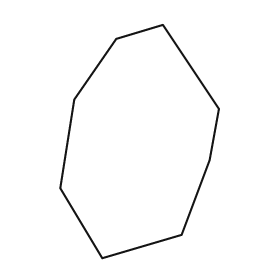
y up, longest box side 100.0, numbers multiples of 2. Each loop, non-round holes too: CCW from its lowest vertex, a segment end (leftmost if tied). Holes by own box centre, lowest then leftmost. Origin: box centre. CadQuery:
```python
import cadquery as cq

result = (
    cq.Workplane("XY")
    .moveTo(-16.0, -50.0)
    .lineTo(18.0, -40.0)
    .lineTo(30.0, -8.0)
    .lineTo(34.0, 14.0)
    .lineTo(10.0, 50.0)
    .lineTo(-10.0, 44.0)
    .lineTo(-28.0, 18.0)
    .lineTo(-34.0, -20.0)
    .close()
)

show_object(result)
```